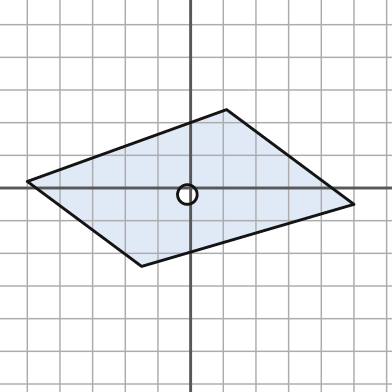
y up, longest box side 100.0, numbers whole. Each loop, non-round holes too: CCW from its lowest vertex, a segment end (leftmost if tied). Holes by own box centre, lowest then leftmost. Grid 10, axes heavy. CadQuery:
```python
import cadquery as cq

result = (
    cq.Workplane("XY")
    .moveTo(-15.0, -24.0)
    .lineTo(50.0, -5.0)
    .lineTo(11.0, 24.0)
    .lineTo(-50.0, 2.0)
    .close()
    .moveTo(-1.0, -2.0)
    .circle(3.0)
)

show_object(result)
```